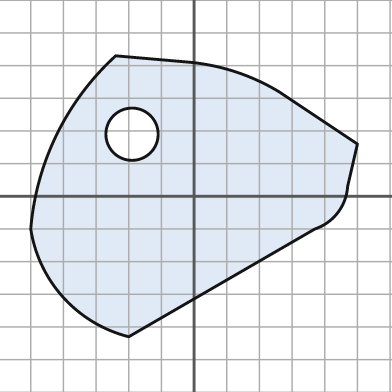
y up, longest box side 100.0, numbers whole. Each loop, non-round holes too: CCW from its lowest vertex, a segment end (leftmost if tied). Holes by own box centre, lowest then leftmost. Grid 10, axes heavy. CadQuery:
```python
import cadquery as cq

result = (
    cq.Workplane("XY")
    .moveTo(-20.0, -43.0)
    .lineTo(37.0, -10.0)
    .threePointArc((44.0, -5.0), (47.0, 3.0))
    .lineTo(50.0, 16.0)
    .lineTo(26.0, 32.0)
    .threePointArc((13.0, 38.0), (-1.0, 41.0))
    .lineTo(-24.0, 43.0)
    .threePointArc((-42.0, 19.0), (-50.0, -10.0))
    .threePointArc((-40.0, -31.0), (-20.0, -43.0))
    .close()
    .moveTo(-19.0, 19.0)
    .circle(8.0)
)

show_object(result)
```